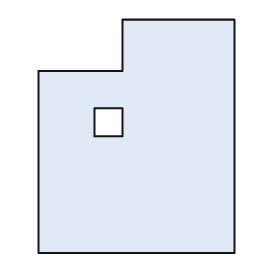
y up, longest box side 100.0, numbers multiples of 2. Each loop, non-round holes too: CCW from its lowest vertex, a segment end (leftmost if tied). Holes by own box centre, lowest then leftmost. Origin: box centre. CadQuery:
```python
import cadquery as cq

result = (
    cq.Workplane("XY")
    .moveTo(-42.0, -50.0)
    .lineTo(42.0, -50.0)
    .lineTo(42.0, 50.0)
    .lineTo(-6.0, 50.0)
    .lineTo(-6.0, 28.0)
    .lineTo(-42.0, 28.0)
    .close()
    .moveTo(-18.0, 0.0)
    .lineTo(-6.0, 0.0)
    .lineTo(-6.0, 12.0)
    .lineTo(-18.0, 12.0)
    .close()
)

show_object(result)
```